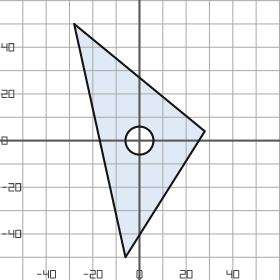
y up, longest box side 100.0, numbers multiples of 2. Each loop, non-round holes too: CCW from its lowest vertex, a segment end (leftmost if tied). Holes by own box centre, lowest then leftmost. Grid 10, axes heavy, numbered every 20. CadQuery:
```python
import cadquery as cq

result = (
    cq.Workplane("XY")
    .moveTo(-6.0, -50.0)
    .lineTo(28.0, 4.0)
    .lineTo(-28.0, 50.0)
    .close()
    .moveTo(0.0, 0.0)
    .circle(6.0)
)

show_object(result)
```